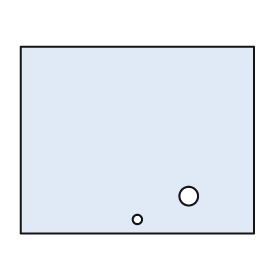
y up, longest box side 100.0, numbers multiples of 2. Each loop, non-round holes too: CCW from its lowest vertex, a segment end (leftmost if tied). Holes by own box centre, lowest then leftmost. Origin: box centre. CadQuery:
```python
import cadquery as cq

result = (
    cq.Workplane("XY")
    .moveTo(-50.0, -40.0)
    .lineTo(50.0, -40.0)
    .lineTo(50.0, 40.0)
    .lineTo(-50.0, 40.0)
    .close()
    .moveTo(0.0, -34.0)
    .circle(2.0)
    .moveTo(22.0, -24.0)
    .circle(4.0)
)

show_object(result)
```